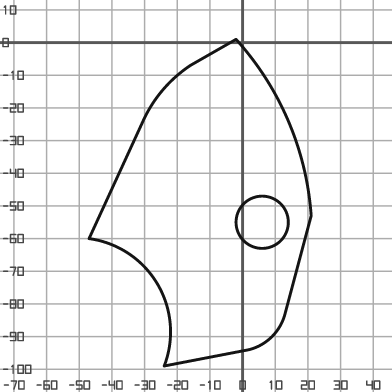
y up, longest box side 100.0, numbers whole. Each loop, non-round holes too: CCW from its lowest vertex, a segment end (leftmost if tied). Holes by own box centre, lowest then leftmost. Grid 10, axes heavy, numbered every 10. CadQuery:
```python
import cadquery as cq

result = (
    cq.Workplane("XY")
    .moveTo(-24.0, -99.0)
    .lineTo(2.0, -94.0)
    .threePointArc((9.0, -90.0), (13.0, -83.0))
    .lineTo(21.0, -53.0)
    .threePointArc((14.0, -24.0), (-2.0, 1.0))
    .lineTo(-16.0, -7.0)
    .threePointArc((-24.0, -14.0), (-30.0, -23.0))
    .lineTo(-47.0, -60.0)
    .threePointArc((-26.0, -74.0), (-24.0, -99.0))
    .close()
    .moveTo(6.0, -55.0)
    .circle(8.0)
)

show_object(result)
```